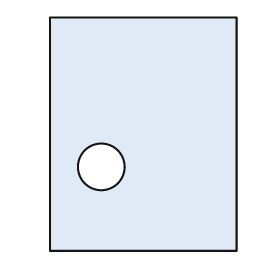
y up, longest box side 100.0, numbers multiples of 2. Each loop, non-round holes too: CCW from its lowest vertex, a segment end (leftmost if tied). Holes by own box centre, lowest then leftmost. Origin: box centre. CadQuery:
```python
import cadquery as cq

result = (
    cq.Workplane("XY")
    .moveTo(-40.0, -50.0)
    .lineTo(40.0, -50.0)
    .lineTo(40.0, 50.0)
    .lineTo(-40.0, 50.0)
    .close()
    .moveTo(-18.0, -14.0)
    .circle(10.0)
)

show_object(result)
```